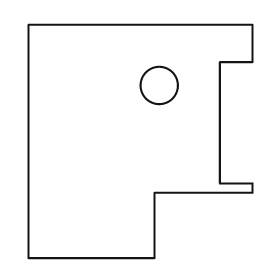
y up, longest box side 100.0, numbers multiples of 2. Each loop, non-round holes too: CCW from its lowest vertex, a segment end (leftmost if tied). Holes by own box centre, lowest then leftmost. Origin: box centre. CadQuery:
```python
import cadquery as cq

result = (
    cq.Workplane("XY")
    .moveTo(-48.0, -50.0)
    .lineTo(6.0, -50.0)
    .lineTo(6.0, -22.0)
    .lineTo(48.0, -22.0)
    .lineTo(48.0, -18.0)
    .lineTo(34.0, -18.0)
    .lineTo(34.0, 34.0)
    .lineTo(48.0, 34.0)
    .lineTo(48.0, 50.0)
    .lineTo(-48.0, 50.0)
    .close()
    .moveTo(8.0, 24.0)
    .circle(8.0)
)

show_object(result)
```